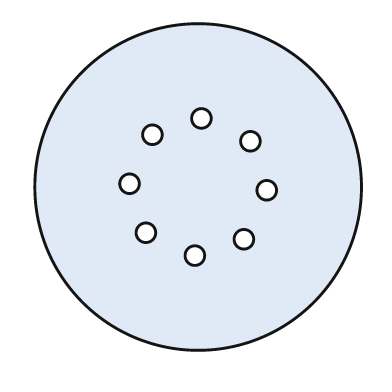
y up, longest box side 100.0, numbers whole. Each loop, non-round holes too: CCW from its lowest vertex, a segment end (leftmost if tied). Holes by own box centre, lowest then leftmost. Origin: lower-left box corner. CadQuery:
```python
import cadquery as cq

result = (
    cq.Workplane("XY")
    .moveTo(50.0, 50.0)
    .circle(50.0)
    .moveTo(49.0, 29.0)
    .circle(3.0)
    .moveTo(64.0, 34.0)
    .circle(3.0)
    .moveTo(34.0, 36.0)
    .circle(3.0)
    .moveTo(71.0, 49.0)
    .circle(3.0)
    .moveTo(29.0, 51.0)
    .circle(3.0)
    .moveTo(66.0, 64.0)
    .circle(3.0)
    .moveTo(36.0, 66.0)
    .circle(3.0)
    .moveTo(51.0, 71.0)
    .circle(3.0)
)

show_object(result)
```